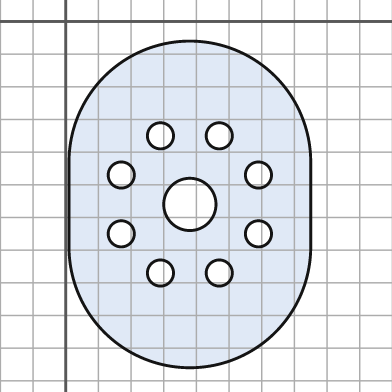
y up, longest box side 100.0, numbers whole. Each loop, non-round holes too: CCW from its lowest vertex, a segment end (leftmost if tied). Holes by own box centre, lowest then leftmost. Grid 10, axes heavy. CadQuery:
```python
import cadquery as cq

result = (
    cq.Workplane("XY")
    .moveTo(1.0, -69.0)
    .threePointArc((38.0, -106.0), (75.0, -69.0))
    .lineTo(75.0, -43.0)
    .threePointArc((38.0, -6.0), (1.0, -43.0))
    .close()
    .moveTo(29.0, -77.0)
    .circle(4.0)
    .moveTo(47.0, -77.0)
    .circle(4.0)
    .moveTo(17.0, -65.0)
    .circle(4.0)
    .moveTo(59.0, -65.0)
    .circle(4.0)
    .moveTo(38.0, -56.0)
    .circle(8.0)
    .moveTo(17.0, -47.0)
    .circle(4.0)
    .moveTo(59.0, -47.0)
    .circle(4.0)
    .moveTo(29.0, -35.0)
    .circle(4.0)
    .moveTo(47.0, -35.0)
    .circle(4.0)
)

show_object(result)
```